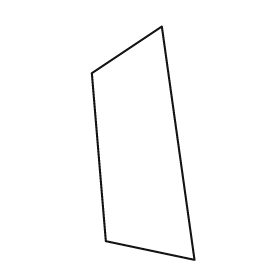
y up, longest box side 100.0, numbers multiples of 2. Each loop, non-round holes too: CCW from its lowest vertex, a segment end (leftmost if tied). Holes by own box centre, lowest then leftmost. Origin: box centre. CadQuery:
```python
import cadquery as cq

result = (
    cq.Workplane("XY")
    .moveTo(22.0, -50.0)
    .lineTo(8.0, 50.0)
    .lineTo(-22.0, 30.0)
    .lineTo(-16.0, -42.0)
    .close()
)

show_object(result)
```